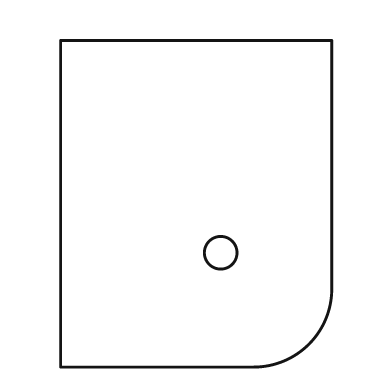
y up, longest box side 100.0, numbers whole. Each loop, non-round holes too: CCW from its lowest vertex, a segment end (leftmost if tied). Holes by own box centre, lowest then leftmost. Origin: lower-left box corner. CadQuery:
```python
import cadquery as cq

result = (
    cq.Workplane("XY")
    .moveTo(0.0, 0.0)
    .lineTo(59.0, 0.0)
    .threePointArc((76.0, 7.0), (83.0, 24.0))
    .lineTo(83.0, 100.0)
    .lineTo(0.0, 100.0)
    .close()
    .moveTo(49.0, 35.0)
    .circle(5.0)
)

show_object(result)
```